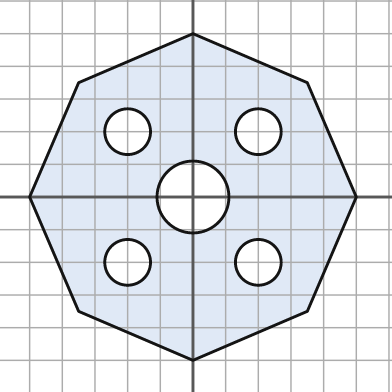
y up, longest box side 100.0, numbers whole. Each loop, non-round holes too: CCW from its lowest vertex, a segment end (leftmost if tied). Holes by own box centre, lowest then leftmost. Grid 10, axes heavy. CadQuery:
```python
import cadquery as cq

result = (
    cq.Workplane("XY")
    .moveTo(0.0, -50.0)
    .lineTo(35.0, -35.0)
    .lineTo(50.0, 0.0)
    .lineTo(35.0, 35.0)
    .lineTo(0.0, 50.0)
    .lineTo(-35.0, 35.0)
    .lineTo(-50.0, 0.0)
    .lineTo(-35.0, -35.0)
    .close()
    .moveTo(-20.0, -20.0)
    .circle(7.0)
    .moveTo(20.0, -20.0)
    .circle(7.0)
    .moveTo(0.0, 0.0)
    .circle(11.0)
    .moveTo(-20.0, 20.0)
    .circle(7.0)
    .moveTo(20.0, 20.0)
    .circle(7.0)
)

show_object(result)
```